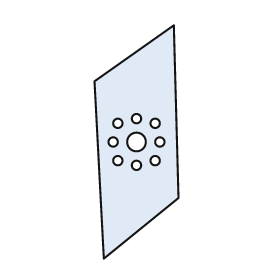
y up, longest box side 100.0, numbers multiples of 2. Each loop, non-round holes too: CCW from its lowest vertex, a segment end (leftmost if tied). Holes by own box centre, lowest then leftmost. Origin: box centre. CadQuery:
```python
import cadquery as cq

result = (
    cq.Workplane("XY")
    .moveTo(-14.0, -50.0)
    .lineTo(18.0, -24.0)
    .lineTo(16.0, 50.0)
    .lineTo(-18.0, 26.0)
    .close()
    .moveTo(0.0, -10.0)
    .circle(2.0)
    .moveTo(-8.0, -8.0)
    .circle(2.0)
    .moveTo(8.0, -8.0)
    .circle(2.0)
    .moveTo(-10.0, 0.0)
    .circle(2.0)
    .moveTo(0.0, 0.0)
    .circle(4.0)
    .moveTo(10.0, 0.0)
    .circle(2.0)
    .moveTo(-8.0, 8.0)
    .circle(2.0)
    .moveTo(8.0, 8.0)
    .circle(2.0)
    .moveTo(0.0, 10.0)
    .circle(2.0)
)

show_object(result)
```